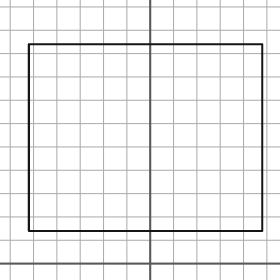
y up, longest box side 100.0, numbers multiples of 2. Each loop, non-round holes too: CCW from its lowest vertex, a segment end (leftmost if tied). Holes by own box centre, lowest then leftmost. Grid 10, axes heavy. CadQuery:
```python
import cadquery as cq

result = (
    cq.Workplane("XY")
    .moveTo(-52.0, 14.0)
    .lineTo(48.0, 14.0)
    .lineTo(48.0, 94.0)
    .lineTo(-52.0, 94.0)
    .close()
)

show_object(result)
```